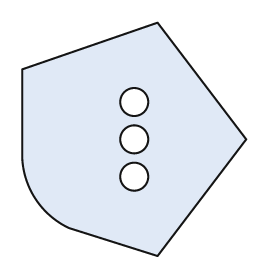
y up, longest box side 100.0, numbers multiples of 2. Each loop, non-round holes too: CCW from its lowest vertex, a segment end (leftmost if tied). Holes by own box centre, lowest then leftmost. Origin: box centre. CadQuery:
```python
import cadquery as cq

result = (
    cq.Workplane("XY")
    .moveTo(10.0, -50.0)
    .lineTo(48.0, 0.0)
    .lineTo(10.0, 50.0)
    .lineTo(-48.0, 30.0)
    .lineTo(-48.0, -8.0)
    .threePointArc((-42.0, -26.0), (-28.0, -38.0))
    .close()
    .moveTo(0.0, -16.0)
    .circle(6.0)
    .moveTo(0.0, 0.0)
    .circle(6.0)
    .moveTo(0.0, 16.0)
    .circle(6.0)
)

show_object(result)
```